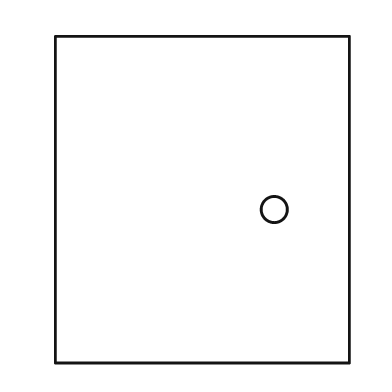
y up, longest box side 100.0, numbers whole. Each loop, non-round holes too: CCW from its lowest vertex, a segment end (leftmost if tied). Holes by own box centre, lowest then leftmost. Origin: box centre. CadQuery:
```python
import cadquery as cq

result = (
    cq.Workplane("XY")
    .moveTo(-45.0, -50.0)
    .lineTo(45.0, -50.0)
    .lineTo(45.0, 50.0)
    .lineTo(-45.0, 50.0)
    .close()
    .moveTo(22.0, -3.0)
    .circle(4.0)
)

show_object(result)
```